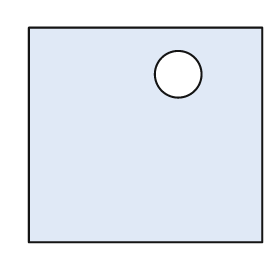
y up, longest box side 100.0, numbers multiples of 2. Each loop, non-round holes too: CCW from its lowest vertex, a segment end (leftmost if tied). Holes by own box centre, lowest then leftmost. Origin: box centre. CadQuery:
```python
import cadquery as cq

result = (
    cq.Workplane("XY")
    .moveTo(-50.0, -46.0)
    .lineTo(50.0, -46.0)
    .lineTo(50.0, 46.0)
    .lineTo(-50.0, 46.0)
    .close()
    .moveTo(14.0, 26.0)
    .circle(10.0)
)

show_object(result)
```